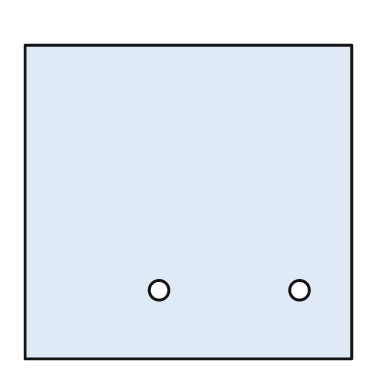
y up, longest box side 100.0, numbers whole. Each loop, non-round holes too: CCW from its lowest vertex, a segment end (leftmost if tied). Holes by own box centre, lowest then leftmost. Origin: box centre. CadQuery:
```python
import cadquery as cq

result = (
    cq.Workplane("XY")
    .moveTo(-50.0, -48.0)
    .lineTo(50.0, -48.0)
    .lineTo(50.0, 48.0)
    .lineTo(-50.0, 48.0)
    .close()
    .moveTo(-9.0, -27.0)
    .circle(3.0)
    .moveTo(34.0, -27.0)
    .circle(3.0)
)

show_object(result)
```